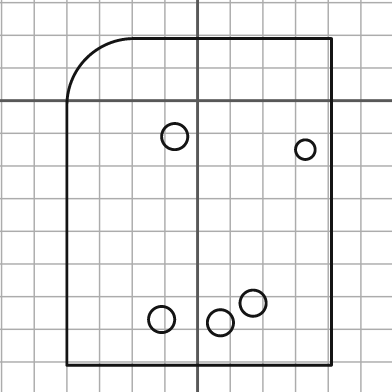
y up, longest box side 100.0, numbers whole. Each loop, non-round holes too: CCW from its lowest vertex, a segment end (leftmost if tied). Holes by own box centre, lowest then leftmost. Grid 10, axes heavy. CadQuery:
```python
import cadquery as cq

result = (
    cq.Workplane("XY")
    .moveTo(-40.0, -81.0)
    .lineTo(41.0, -81.0)
    .lineTo(41.0, 19.0)
    .lineTo(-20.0, 19.0)
    .threePointArc((-34.0, 13.0), (-40.0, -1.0))
    .close()
    .moveTo(7.0, -68.0)
    .circle(4.0)
    .moveTo(-11.0, -67.0)
    .circle(4.0)
    .moveTo(17.0, -62.0)
    .circle(4.0)
    .moveTo(33.0, -15.0)
    .circle(3.0)
    .moveTo(-7.0, -11.0)
    .circle(4.0)
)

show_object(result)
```